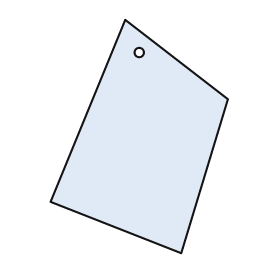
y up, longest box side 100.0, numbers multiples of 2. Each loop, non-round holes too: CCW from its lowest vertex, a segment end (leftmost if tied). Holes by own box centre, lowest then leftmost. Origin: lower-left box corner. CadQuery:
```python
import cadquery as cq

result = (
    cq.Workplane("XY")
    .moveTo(56.0, 0.0)
    .lineTo(76.0, 66.0)
    .lineTo(32.0, 100.0)
    .lineTo(0.0, 22.0)
    .close()
    .moveTo(38.0, 86.0)
    .circle(2.0)
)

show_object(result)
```